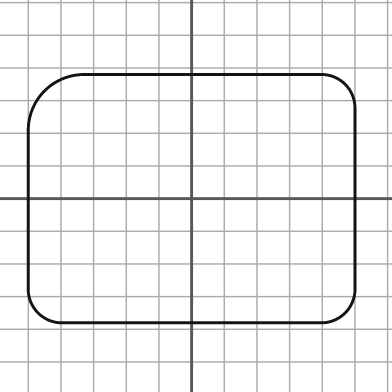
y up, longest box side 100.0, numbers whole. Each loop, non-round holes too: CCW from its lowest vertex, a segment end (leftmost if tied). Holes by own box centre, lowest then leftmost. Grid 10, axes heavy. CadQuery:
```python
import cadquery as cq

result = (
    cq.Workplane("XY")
    .moveTo(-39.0, -38.0)
    .lineTo(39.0, -38.0)
    .threePointArc((47.0, -35.0), (50.0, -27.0))
    .lineTo(50.0, 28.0)
    .threePointArc((47.0, 35.0), (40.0, 38.0))
    .lineTo(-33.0, 38.0)
    .threePointArc((-45.0, 33.0), (-50.0, 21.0))
    .lineTo(-50.0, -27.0)
    .threePointArc((-47.0, -35.0), (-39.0, -38.0))
    .close()
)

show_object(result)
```